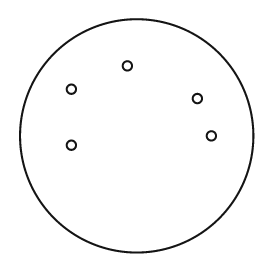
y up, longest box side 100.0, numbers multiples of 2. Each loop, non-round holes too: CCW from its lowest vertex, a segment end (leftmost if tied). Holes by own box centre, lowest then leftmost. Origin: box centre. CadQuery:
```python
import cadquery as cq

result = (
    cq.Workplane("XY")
    .moveTo(0.0, 0.0)
    .circle(50.0)
    .moveTo(-28.0, -4.0)
    .circle(2.0)
    .moveTo(32.0, 0.0)
    .circle(2.0)
    .moveTo(26.0, 16.0)
    .circle(2.0)
    .moveTo(-28.0, 20.0)
    .circle(2.0)
    .moveTo(-4.0, 30.0)
    .circle(2.0)
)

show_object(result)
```